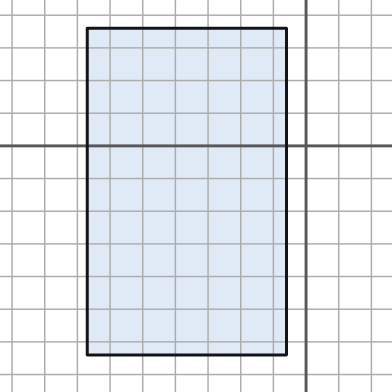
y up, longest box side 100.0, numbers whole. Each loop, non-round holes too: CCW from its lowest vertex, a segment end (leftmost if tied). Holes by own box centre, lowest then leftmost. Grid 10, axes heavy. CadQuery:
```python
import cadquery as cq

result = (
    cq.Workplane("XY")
    .moveTo(-67.0, -64.0)
    .lineTo(-6.0, -64.0)
    .lineTo(-6.0, 36.0)
    .lineTo(-67.0, 36.0)
    .close()
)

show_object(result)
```